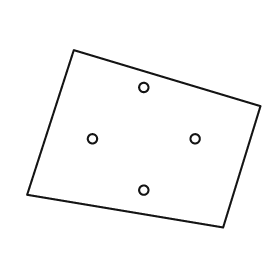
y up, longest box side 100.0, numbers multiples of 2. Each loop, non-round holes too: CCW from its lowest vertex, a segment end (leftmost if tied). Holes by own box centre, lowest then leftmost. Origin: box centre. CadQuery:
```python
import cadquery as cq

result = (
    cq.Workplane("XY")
    .moveTo(34.0, -38.0)
    .lineTo(50.0, 14.0)
    .lineTo(-30.0, 38.0)
    .lineTo(-50.0, -24.0)
    .close()
    .moveTo(0.0, -22.0)
    .circle(2.0)
    .moveTo(-22.0, 0.0)
    .circle(2.0)
    .moveTo(22.0, 0.0)
    .circle(2.0)
    .moveTo(0.0, 22.0)
    .circle(2.0)
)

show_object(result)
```